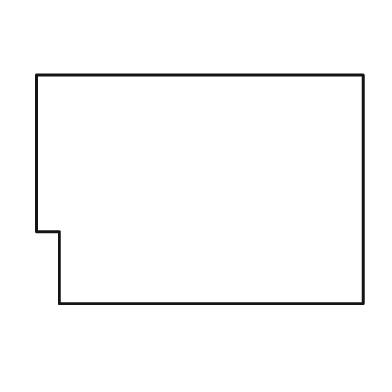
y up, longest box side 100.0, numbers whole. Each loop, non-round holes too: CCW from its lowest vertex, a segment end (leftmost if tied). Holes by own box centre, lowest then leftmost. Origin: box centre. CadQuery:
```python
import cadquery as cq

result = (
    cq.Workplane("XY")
    .moveTo(-43.0, -35.0)
    .lineTo(50.0, -35.0)
    .lineTo(50.0, 35.0)
    .lineTo(-50.0, 35.0)
    .lineTo(-50.0, -13.0)
    .lineTo(-43.0, -13.0)
    .close()
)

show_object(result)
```